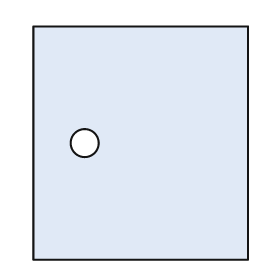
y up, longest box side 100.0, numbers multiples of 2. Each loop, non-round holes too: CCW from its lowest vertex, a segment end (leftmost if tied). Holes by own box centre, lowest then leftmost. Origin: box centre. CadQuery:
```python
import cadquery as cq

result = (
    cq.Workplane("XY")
    .moveTo(-46.0, -50.0)
    .lineTo(46.0, -50.0)
    .lineTo(46.0, 50.0)
    .lineTo(-46.0, 50.0)
    .close()
    .moveTo(-24.0, 0.0)
    .circle(6.0)
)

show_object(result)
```